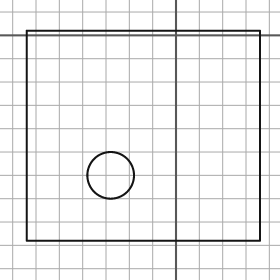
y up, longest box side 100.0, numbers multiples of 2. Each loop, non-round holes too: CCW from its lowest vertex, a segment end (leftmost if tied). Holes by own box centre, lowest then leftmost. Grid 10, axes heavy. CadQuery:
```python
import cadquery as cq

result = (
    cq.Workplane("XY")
    .moveTo(-64.0, -88.0)
    .lineTo(36.0, -88.0)
    .lineTo(36.0, 2.0)
    .lineTo(-64.0, 2.0)
    .close()
    .moveTo(-28.0, -60.0)
    .circle(10.0)
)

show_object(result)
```